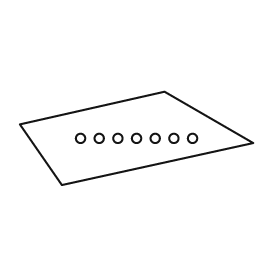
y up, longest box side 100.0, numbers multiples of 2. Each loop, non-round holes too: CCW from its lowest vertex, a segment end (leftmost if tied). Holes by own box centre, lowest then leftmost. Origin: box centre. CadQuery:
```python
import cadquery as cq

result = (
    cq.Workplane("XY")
    .moveTo(-32.0, -20.0)
    .lineTo(50.0, -2.0)
    .lineTo(12.0, 20.0)
    .lineTo(-50.0, 6.0)
    .close()
    .moveTo(-24.0, 0.0)
    .circle(2.0)
    .moveTo(-16.0, 0.0)
    .circle(2.0)
    .moveTo(-8.0, 0.0)
    .circle(2.0)
    .moveTo(0.0, 0.0)
    .circle(2.0)
    .moveTo(8.0, 0.0)
    .circle(2.0)
    .moveTo(16.0, 0.0)
    .circle(2.0)
    .moveTo(24.0, 0.0)
    .circle(2.0)
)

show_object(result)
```